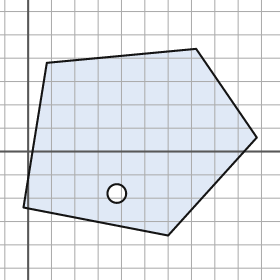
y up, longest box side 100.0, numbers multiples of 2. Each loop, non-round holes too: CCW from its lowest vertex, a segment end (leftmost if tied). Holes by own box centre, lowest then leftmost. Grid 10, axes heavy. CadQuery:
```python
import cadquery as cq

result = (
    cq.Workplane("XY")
    .moveTo(60.0, -36.0)
    .lineTo(98.0, 6.0)
    .lineTo(72.0, 44.0)
    .lineTo(8.0, 38.0)
    .lineTo(-2.0, -24.0)
    .close()
    .moveTo(38.0, -18.0)
    .circle(4.0)
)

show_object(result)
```